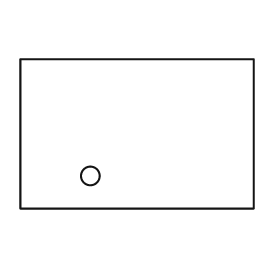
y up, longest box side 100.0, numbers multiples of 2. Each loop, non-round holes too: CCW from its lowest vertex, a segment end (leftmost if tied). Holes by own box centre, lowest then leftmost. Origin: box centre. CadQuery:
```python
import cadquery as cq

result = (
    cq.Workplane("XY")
    .moveTo(-50.0, -32.0)
    .lineTo(50.0, -32.0)
    .lineTo(50.0, 32.0)
    .lineTo(-50.0, 32.0)
    .close()
    .moveTo(-20.0, -18.0)
    .circle(4.0)
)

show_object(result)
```